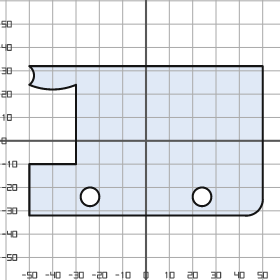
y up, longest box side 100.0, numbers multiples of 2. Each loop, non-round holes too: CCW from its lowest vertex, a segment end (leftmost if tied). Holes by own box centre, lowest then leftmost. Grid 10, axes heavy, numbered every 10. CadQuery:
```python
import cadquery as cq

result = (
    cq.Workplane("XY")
    .moveTo(-50.0, -32.0)
    .lineTo(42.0, -32.0)
    .threePointArc((48.0, -30.0), (50.0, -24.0))
    .lineTo(50.0, 32.0)
    .lineTo(-50.0, 32.0)
    .threePointArc((-48.0, 28.0), (-50.0, 24.0))
    .threePointArc((-40.0, 22.0), (-30.0, 24.0))
    .lineTo(-30.0, -10.0)
    .lineTo(-50.0, -10.0)
    .close()
    .moveTo(-24.0, -24.0)
    .circle(4.0)
    .moveTo(24.0, -24.0)
    .circle(4.0)
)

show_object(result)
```